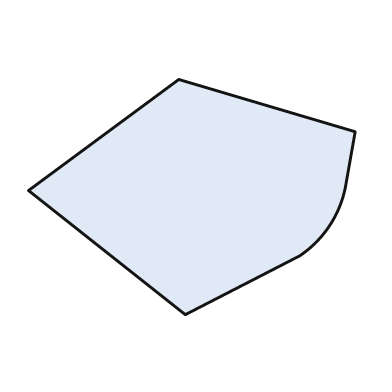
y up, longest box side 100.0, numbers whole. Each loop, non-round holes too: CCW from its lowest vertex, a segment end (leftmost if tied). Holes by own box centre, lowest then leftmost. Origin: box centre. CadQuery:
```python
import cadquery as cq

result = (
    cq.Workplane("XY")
    .moveTo(-2.0, -36.0)
    .lineTo(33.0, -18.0)
    .threePointArc((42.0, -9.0), (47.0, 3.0))
    .lineTo(50.0, 20.0)
    .lineTo(-4.0, 36.0)
    .lineTo(-50.0, 2.0)
    .close()
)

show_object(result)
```